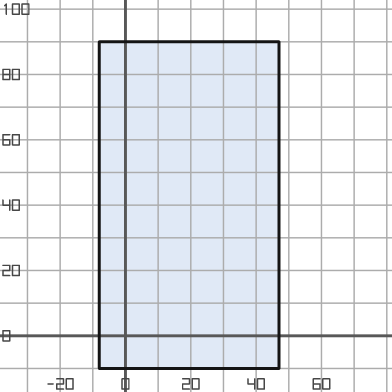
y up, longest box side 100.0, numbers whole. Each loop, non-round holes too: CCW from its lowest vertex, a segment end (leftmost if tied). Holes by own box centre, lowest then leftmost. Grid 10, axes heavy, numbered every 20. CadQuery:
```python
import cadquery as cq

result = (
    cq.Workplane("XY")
    .moveTo(-8.0, -10.0)
    .lineTo(47.0, -10.0)
    .lineTo(47.0, 90.0)
    .lineTo(-8.0, 90.0)
    .close()
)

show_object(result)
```